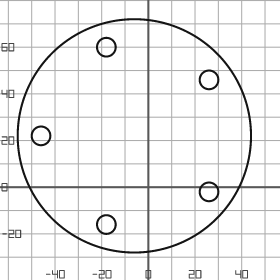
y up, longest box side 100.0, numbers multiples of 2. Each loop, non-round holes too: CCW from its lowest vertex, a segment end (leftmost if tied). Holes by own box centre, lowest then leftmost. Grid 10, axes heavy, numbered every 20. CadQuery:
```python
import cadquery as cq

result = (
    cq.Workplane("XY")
    .moveTo(-6.0, 22.0)
    .circle(50.0)
    .moveTo(-18.0, -16.0)
    .circle(4.0)
    .moveTo(26.0, -2.0)
    .circle(4.0)
    .moveTo(-46.0, 22.0)
    .circle(4.0)
    .moveTo(26.0, 46.0)
    .circle(4.0)
    .moveTo(-18.0, 60.0)
    .circle(4.0)
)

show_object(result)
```